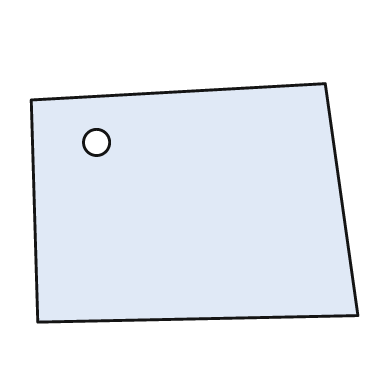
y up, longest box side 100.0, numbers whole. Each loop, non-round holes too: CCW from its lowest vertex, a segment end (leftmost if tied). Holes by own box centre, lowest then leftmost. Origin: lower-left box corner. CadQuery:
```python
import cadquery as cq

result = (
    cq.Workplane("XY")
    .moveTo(2.0, 0.0)
    .lineTo(100.0, 2.0)
    .lineTo(90.0, 73.0)
    .lineTo(0.0, 68.0)
    .close()
    .moveTo(20.0, 55.0)
    .circle(4.0)
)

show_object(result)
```